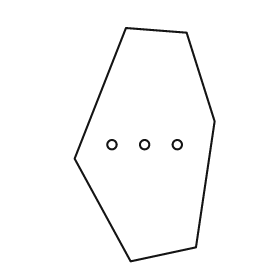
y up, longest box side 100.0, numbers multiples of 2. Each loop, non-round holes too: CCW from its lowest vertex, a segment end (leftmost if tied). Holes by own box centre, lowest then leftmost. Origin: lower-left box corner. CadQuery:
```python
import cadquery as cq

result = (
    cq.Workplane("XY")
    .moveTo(24.0, 0.0)
    .lineTo(52.0, 6.0)
    .lineTo(60.0, 60.0)
    .lineTo(48.0, 98.0)
    .lineTo(22.0, 100.0)
    .lineTo(0.0, 44.0)
    .close()
    .moveTo(16.0, 50.0)
    .circle(2.0)
    .moveTo(30.0, 50.0)
    .circle(2.0)
    .moveTo(44.0, 50.0)
    .circle(2.0)
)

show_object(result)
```